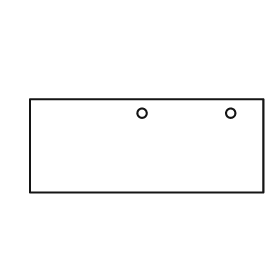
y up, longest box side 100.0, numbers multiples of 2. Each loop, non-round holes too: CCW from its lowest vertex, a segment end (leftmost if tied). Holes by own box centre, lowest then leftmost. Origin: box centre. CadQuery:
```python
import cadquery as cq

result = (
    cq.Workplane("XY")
    .moveTo(-50.0, -20.0)
    .lineTo(50.0, -20.0)
    .lineTo(50.0, 20.0)
    .lineTo(-50.0, 20.0)
    .close()
    .moveTo(-2.0, 14.0)
    .circle(2.0)
    .moveTo(36.0, 14.0)
    .circle(2.0)
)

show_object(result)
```